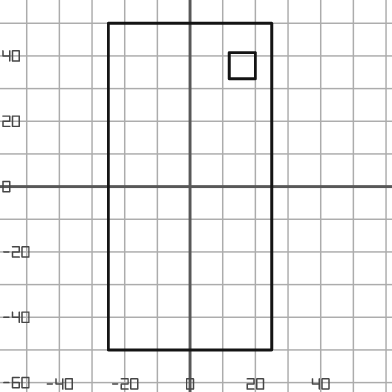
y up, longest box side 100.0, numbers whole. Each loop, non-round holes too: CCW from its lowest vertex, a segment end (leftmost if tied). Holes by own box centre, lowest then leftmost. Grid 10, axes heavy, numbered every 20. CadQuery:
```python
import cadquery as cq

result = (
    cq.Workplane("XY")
    .moveTo(-25.0, -50.0)
    .lineTo(25.0, -50.0)
    .lineTo(25.0, 50.0)
    .lineTo(-25.0, 50.0)
    .close()
    .moveTo(12.0, 33.0)
    .lineTo(20.0, 33.0)
    .lineTo(20.0, 41.0)
    .lineTo(12.0, 41.0)
    .close()
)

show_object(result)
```